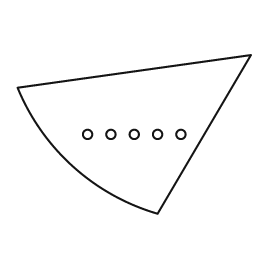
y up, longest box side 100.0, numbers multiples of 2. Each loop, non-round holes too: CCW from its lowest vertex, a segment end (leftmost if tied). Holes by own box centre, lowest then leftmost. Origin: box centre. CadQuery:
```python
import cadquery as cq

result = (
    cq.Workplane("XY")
    .moveTo(10.0, -34.0)
    .lineTo(50.0, 34.0)
    .lineTo(-50.0, 20.0)
    .threePointArc((-26.0, -14.0), (10.0, -34.0))
    .close()
    .moveTo(-20.0, 0.0)
    .circle(2.0)
    .moveTo(-10.0, 0.0)
    .circle(2.0)
    .moveTo(0.0, 0.0)
    .circle(2.0)
    .moveTo(10.0, 0.0)
    .circle(2.0)
    .moveTo(20.0, 0.0)
    .circle(2.0)
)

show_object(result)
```